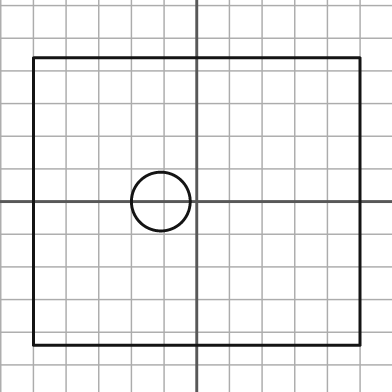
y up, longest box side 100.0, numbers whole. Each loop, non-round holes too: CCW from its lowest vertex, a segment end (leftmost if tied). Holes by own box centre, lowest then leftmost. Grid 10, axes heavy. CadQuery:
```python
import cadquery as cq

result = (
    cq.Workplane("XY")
    .moveTo(-50.0, -44.0)
    .lineTo(50.0, -44.0)
    .lineTo(50.0, 44.0)
    .lineTo(-50.0, 44.0)
    .close()
    .moveTo(-11.0, 0.0)
    .circle(9.0)
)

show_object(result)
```